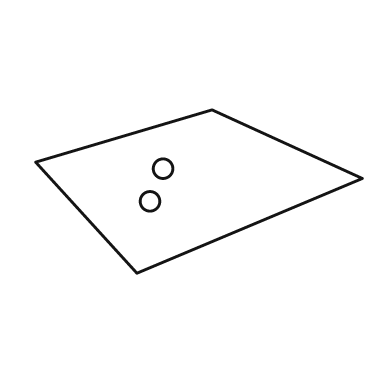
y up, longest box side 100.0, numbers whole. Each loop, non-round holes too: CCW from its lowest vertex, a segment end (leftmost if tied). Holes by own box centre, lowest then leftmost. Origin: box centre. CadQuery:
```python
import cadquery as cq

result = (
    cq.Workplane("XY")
    .moveTo(-19.0, -25.0)
    .lineTo(50.0, 4.0)
    .lineTo(4.0, 25.0)
    .lineTo(-50.0, 9.0)
    .close()
    .moveTo(-15.0, -3.0)
    .circle(3.0)
    .moveTo(-11.0, 7.0)
    .circle(3.0)
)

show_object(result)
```